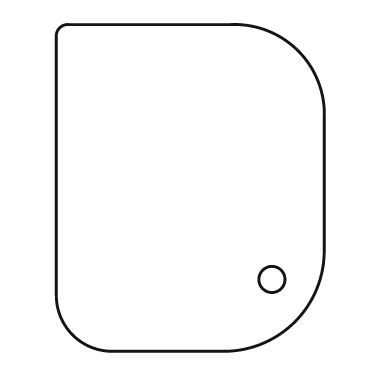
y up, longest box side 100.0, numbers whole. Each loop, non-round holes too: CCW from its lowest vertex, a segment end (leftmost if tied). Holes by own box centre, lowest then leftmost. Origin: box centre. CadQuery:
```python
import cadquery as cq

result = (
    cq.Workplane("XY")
    .moveTo(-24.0, -50.0)
    .lineTo(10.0, -50.0)
    .threePointArc((32.0, -41.0), (41.0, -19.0))
    .lineTo(41.0, 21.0)
    .threePointArc((33.0, 42.0), (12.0, 50.0))
    .lineTo(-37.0, 50.0)
    .threePointArc((-40.0, 49.0), (-41.0, 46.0))
    .lineTo(-41.0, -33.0)
    .threePointArc((-36.0, -45.0), (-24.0, -50.0))
    .close()
    .moveTo(25.0, -28.0)
    .circle(4.0)
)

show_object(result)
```